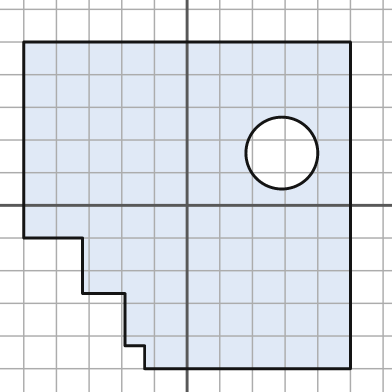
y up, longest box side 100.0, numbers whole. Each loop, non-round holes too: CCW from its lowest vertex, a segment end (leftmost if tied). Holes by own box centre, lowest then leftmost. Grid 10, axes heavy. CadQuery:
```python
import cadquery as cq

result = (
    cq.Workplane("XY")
    .moveTo(-13.0, -50.0)
    .lineTo(50.0, -50.0)
    .lineTo(50.0, 50.0)
    .lineTo(-50.0, 50.0)
    .lineTo(-50.0, -10.0)
    .lineTo(-32.0, -10.0)
    .lineTo(-32.0, -27.0)
    .lineTo(-19.0, -27.0)
    .lineTo(-19.0, -43.0)
    .lineTo(-13.0, -43.0)
    .close()
    .moveTo(29.0, 16.0)
    .circle(11.0)
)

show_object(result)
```